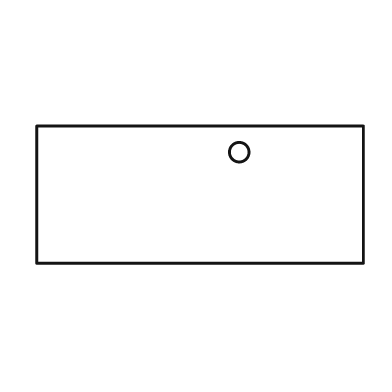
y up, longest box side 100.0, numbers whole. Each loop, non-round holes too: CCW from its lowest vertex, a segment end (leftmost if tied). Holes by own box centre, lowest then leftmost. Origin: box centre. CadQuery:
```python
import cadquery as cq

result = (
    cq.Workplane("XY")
    .moveTo(-50.0, -21.0)
    .lineTo(50.0, -21.0)
    .lineTo(50.0, 21.0)
    .lineTo(-50.0, 21.0)
    .close()
    .moveTo(12.0, 13.0)
    .circle(3.0)
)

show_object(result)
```